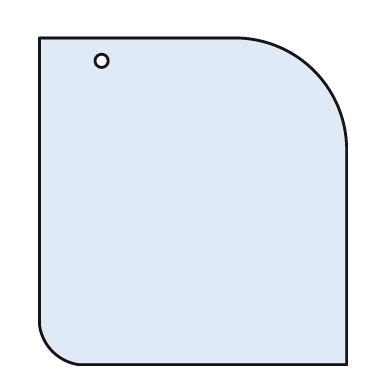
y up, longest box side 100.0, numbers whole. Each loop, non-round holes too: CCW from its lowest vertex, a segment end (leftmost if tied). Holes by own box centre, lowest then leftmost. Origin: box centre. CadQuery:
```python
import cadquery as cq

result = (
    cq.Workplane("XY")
    .moveTo(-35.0, -50.0)
    .lineTo(47.0, -50.0)
    .lineTo(47.0, 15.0)
    .threePointArc((37.0, 40.0), (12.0, 50.0))
    .lineTo(-47.0, 50.0)
    .lineTo(-47.0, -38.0)
    .threePointArc((-43.0, -46.0), (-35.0, -50.0))
    .close()
    .moveTo(-28.0, 43.0)
    .circle(2.0)
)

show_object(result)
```